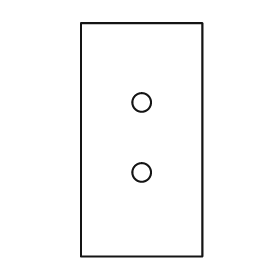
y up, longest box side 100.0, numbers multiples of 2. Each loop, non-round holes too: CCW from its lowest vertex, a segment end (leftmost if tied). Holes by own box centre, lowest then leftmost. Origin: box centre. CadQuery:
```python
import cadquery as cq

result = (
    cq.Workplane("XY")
    .moveTo(-26.0, -50.0)
    .lineTo(26.0, -50.0)
    .lineTo(26.0, 50.0)
    .lineTo(-26.0, 50.0)
    .close()
    .moveTo(0.0, -14.0)
    .circle(4.0)
    .moveTo(0.0, 16.0)
    .circle(4.0)
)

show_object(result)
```